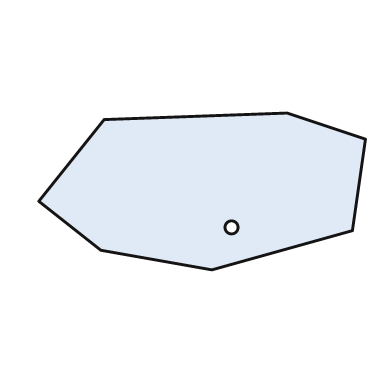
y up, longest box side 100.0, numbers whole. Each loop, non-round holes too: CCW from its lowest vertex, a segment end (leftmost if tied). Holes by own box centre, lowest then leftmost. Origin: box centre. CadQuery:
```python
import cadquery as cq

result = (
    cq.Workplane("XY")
    .moveTo(3.0, -24.0)
    .lineTo(46.0, -12.0)
    .lineTo(50.0, 16.0)
    .lineTo(26.0, 24.0)
    .lineTo(-30.0, 22.0)
    .lineTo(-50.0, -3.0)
    .lineTo(-31.0, -18.0)
    .close()
    .moveTo(9.0, -11.0)
    .circle(2.0)
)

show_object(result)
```